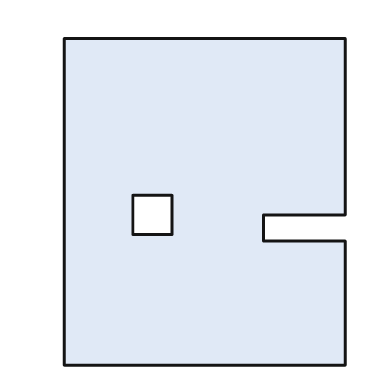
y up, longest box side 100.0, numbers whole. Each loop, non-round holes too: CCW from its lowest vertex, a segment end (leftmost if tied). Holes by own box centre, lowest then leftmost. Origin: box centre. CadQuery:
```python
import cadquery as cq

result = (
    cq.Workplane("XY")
    .moveTo(-43.0, -50.0)
    .lineTo(43.0, -50.0)
    .lineTo(43.0, -12.0)
    .lineTo(18.0, -12.0)
    .lineTo(18.0, -4.0)
    .lineTo(43.0, -4.0)
    .lineTo(43.0, 50.0)
    .lineTo(-43.0, 50.0)
    .close()
    .moveTo(-22.0, -10.0)
    .lineTo(-10.0, -10.0)
    .lineTo(-10.0, 2.0)
    .lineTo(-22.0, 2.0)
    .close()
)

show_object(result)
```